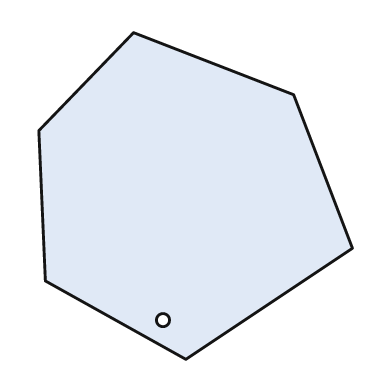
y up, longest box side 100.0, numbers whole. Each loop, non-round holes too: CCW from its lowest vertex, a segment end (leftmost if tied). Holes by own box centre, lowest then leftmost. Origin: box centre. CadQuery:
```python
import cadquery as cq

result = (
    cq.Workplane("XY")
    .moveTo(-3.0, -50.0)
    .lineTo(48.0, -16.0)
    .lineTo(30.0, 31.0)
    .lineTo(-19.0, 50.0)
    .lineTo(-48.0, 20.0)
    .lineTo(-46.0, -26.0)
    .close()
    .moveTo(-10.0, -38.0)
    .circle(2.0)
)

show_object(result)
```